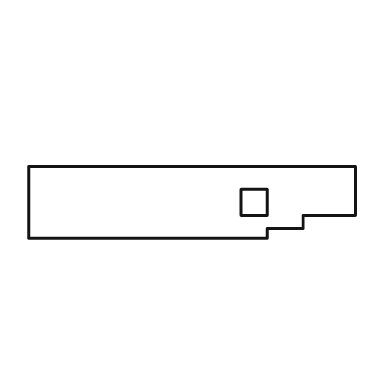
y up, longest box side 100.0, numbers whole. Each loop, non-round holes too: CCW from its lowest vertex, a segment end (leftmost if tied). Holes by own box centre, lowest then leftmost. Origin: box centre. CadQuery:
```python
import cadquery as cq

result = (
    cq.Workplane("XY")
    .moveTo(-50.0, -11.0)
    .lineTo(23.0, -11.0)
    .lineTo(23.0, -8.0)
    .lineTo(34.0, -8.0)
    .lineTo(34.0, -4.0)
    .lineTo(50.0, -4.0)
    .lineTo(50.0, 11.0)
    .lineTo(-50.0, 11.0)
    .close()
    .moveTo(15.0, -4.0)
    .lineTo(23.0, -4.0)
    .lineTo(23.0, 4.0)
    .lineTo(15.0, 4.0)
    .close()
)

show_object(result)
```